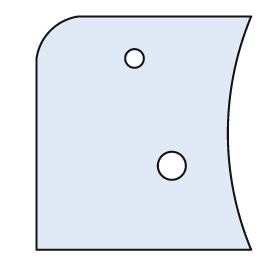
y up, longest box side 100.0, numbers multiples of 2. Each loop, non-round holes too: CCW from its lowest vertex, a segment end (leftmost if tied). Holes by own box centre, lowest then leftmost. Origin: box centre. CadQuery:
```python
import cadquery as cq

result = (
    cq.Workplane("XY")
    .moveTo(-46.0, -50.0)
    .lineTo(46.0, -50.0)
    .threePointArc((36.0, 0.0), (46.0, 50.0))
    .lineTo(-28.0, 50.0)
    .threePointArc((-40.0, 44.0), (-46.0, 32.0))
    .close()
    .moveTo(12.0, -14.0)
    .circle(6.0)
    .moveTo(-4.0, 32.0)
    .circle(4.0)
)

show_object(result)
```